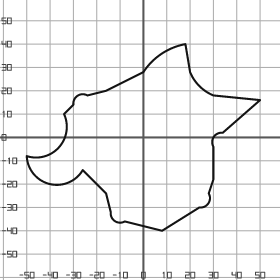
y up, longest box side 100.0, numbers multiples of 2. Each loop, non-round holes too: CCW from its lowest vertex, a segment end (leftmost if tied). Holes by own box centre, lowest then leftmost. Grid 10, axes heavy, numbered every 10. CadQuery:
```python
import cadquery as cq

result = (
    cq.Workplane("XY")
    .moveTo(8.0, -40.0)
    .lineTo(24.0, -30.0)
    .threePointArc((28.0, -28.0), (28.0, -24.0))
    .lineTo(30.0, -18.0)
    .lineTo(30.0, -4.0)
    .threePointArc((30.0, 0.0), (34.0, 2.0))
    .lineTo(50.0, 16.0)
    .lineTo(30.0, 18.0)
    .threePointArc((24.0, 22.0), (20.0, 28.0))
    .lineTo(18.0, 40.0)
    .threePointArc((8.0, 36.0), (0.0, 28.0))
    .lineTo(-16.0, 20.0)
    .lineTo(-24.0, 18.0)
    .threePointArc((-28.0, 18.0), (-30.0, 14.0))
    .lineTo(-34.0, 10.0)
    .threePointArc((-36.0, -4.0), (-50.0, -8.0))
    .threePointArc((-40.0, -20.0), (-26.0, -14.0))
    .lineTo(-16.0, -24.0)
    .lineTo(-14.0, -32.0)
    .threePointArc((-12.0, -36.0), (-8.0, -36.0))
    .close()
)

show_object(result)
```